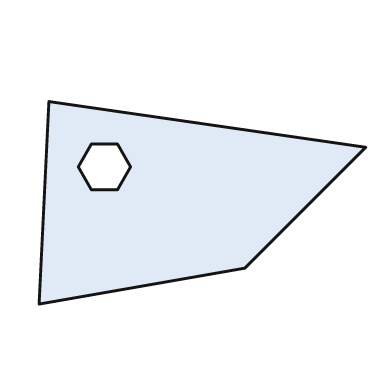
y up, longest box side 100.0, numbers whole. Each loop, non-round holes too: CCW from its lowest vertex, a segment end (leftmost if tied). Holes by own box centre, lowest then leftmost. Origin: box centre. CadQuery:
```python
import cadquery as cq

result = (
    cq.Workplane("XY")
    .moveTo(-50.0, -31.0)
    .lineTo(13.0, -20.0)
    .lineTo(50.0, 17.0)
    .lineTo(-47.0, 31.0)
    .close()
    .moveTo(-34.0, 4.0)
    .lineTo(-26.0, 4.0)
    .lineTo(-22.0, 11.0)
    .lineTo(-26.0, 18.0)
    .lineTo(-34.0, 18.0)
    .lineTo(-38.0, 11.0)
    .close()
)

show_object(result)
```